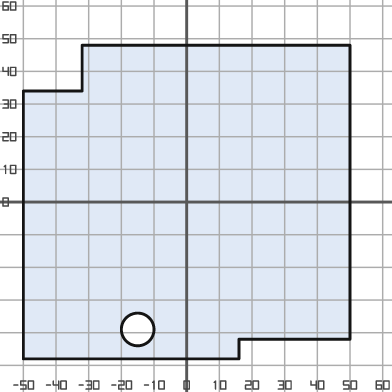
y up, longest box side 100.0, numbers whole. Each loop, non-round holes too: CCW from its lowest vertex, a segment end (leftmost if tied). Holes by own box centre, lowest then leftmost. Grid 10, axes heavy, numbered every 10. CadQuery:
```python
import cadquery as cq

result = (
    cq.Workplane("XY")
    .moveTo(-50.0, -48.0)
    .lineTo(16.0, -48.0)
    .lineTo(16.0, -42.0)
    .lineTo(50.0, -42.0)
    .lineTo(50.0, 48.0)
    .lineTo(-32.0, 48.0)
    .lineTo(-32.0, 34.0)
    .lineTo(-50.0, 34.0)
    .close()
    .moveTo(-15.0, -39.0)
    .circle(5.0)
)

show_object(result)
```